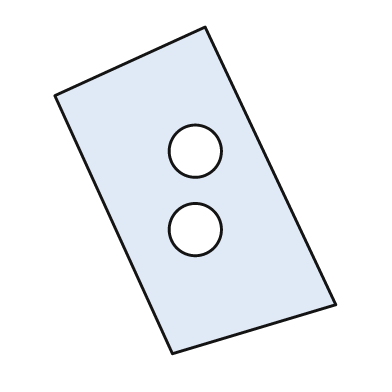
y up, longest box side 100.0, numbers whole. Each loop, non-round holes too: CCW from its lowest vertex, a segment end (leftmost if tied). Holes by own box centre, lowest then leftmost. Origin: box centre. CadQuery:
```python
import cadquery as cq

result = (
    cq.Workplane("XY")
    .moveTo(-7.0, -50.0)
    .lineTo(43.0, -35.0)
    .lineTo(3.0, 50.0)
    .lineTo(-43.0, 29.0)
    .close()
    .moveTo(0.0, -12.0)
    .circle(8.0)
    .moveTo(0.0, 12.0)
    .circle(8.0)
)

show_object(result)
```